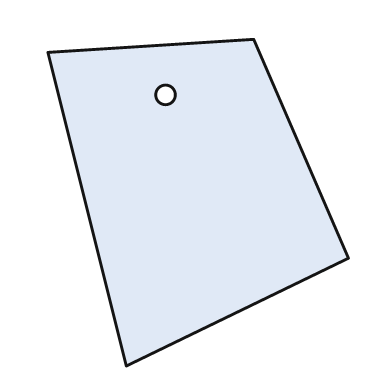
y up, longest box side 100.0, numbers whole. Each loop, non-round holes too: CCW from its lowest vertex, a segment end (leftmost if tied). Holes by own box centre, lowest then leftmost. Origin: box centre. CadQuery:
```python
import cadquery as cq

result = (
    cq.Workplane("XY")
    .moveTo(-22.0, -50.0)
    .lineTo(46.0, -17.0)
    .lineTo(17.0, 50.0)
    .lineTo(-46.0, 46.0)
    .close()
    .moveTo(-10.0, 33.0)
    .circle(3.0)
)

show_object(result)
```